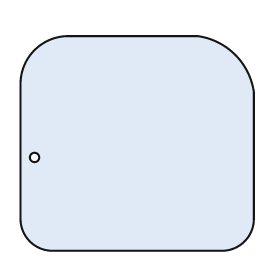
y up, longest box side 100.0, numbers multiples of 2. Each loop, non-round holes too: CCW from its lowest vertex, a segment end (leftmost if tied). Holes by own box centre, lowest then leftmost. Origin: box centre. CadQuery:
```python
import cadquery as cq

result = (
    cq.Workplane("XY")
    .moveTo(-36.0, -46.0)
    .lineTo(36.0, -46.0)
    .threePointArc((46.0, -42.0), (50.0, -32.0))
    .lineTo(50.0, 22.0)
    .threePointArc((42.0, 38.0), (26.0, 46.0))
    .lineTo(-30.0, 46.0)
    .threePointArc((-44.0, 40.0), (-50.0, 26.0))
    .lineTo(-50.0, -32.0)
    .threePointArc((-46.0, -42.0), (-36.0, -46.0))
    .close()
    .moveTo(-44.0, -6.0)
    .circle(2.0)
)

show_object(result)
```